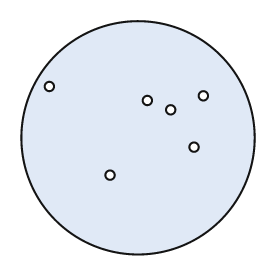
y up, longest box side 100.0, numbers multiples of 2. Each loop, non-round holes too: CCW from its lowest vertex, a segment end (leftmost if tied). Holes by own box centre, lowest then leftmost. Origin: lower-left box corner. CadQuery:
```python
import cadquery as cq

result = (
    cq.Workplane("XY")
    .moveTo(50.0, 50.0)
    .circle(50.0)
    .moveTo(38.0, 34.0)
    .circle(2.0)
    .moveTo(74.0, 46.0)
    .circle(2.0)
    .moveTo(64.0, 62.0)
    .circle(2.0)
    .moveTo(54.0, 66.0)
    .circle(2.0)
    .moveTo(78.0, 68.0)
    .circle(2.0)
    .moveTo(12.0, 72.0)
    .circle(2.0)
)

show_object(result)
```